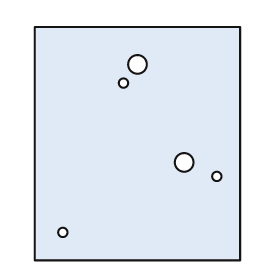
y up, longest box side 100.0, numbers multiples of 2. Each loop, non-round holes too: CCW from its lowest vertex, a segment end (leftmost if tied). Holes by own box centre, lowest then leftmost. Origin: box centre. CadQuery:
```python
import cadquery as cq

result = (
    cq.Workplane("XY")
    .moveTo(-44.0, -50.0)
    .lineTo(44.0, -50.0)
    .lineTo(44.0, 50.0)
    .lineTo(-44.0, 50.0)
    .close()
    .moveTo(-32.0, -38.0)
    .circle(2.0)
    .moveTo(34.0, -14.0)
    .circle(2.0)
    .moveTo(20.0, -8.0)
    .circle(4.0)
    .moveTo(-6.0, 26.0)
    .circle(2.0)
    .moveTo(0.0, 34.0)
    .circle(4.0)
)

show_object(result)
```